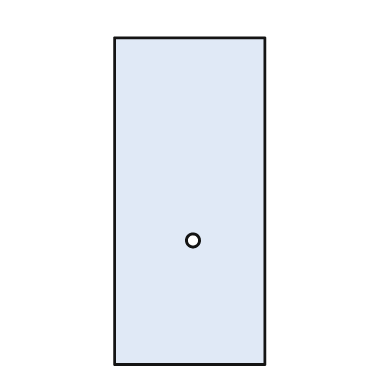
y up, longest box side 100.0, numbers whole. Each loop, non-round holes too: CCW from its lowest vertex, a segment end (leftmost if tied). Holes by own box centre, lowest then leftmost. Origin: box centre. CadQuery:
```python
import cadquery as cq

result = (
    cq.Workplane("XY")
    .moveTo(-23.0, -50.0)
    .lineTo(23.0, -50.0)
    .lineTo(23.0, 50.0)
    .lineTo(-23.0, 50.0)
    .close()
    .moveTo(1.0, -12.0)
    .circle(2.0)
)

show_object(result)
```